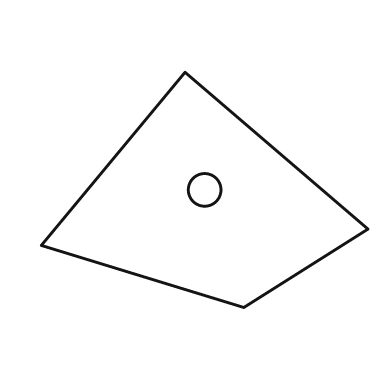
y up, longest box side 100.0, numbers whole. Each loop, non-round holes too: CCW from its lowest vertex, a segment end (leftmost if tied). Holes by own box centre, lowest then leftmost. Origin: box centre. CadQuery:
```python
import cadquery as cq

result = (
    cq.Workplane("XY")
    .moveTo(12.0, -36.0)
    .lineTo(50.0, -12.0)
    .lineTo(-6.0, 36.0)
    .lineTo(-50.0, -17.0)
    .close()
    .moveTo(0.0, 0.0)
    .circle(5.0)
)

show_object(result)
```